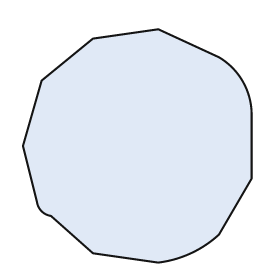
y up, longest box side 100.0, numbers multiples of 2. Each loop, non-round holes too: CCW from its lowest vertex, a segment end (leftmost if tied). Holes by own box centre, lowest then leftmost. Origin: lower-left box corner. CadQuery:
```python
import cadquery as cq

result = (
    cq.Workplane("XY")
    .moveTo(58.0, 0.0)
    .threePointArc((72.0, 4.0), (84.0, 12.0))
    .lineTo(98.0, 36.0)
    .lineTo(98.0, 64.0)
    .threePointArc((94.0, 78.0), (84.0, 88.0))
    .lineTo(58.0, 100.0)
    .lineTo(30.0, 96.0)
    .lineTo(8.0, 78.0)
    .lineTo(0.0, 50.0)
    .lineTo(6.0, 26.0)
    .threePointArc((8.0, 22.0), (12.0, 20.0))
    .lineTo(30.0, 4.0)
    .close()
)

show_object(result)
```